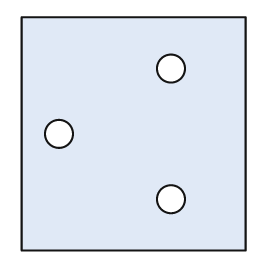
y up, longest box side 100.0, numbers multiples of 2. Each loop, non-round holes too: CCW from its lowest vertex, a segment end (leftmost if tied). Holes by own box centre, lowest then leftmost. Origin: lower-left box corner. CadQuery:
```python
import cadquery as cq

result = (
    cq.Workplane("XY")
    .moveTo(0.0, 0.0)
    .lineTo(96.0, 0.0)
    .lineTo(96.0, 100.0)
    .lineTo(0.0, 100.0)
    .close()
    .moveTo(64.0, 22.0)
    .circle(6.0)
    .moveTo(16.0, 50.0)
    .circle(6.0)
    .moveTo(64.0, 78.0)
    .circle(6.0)
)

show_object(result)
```